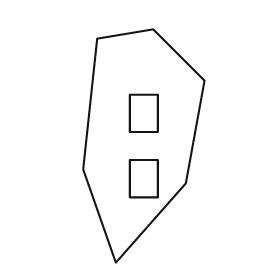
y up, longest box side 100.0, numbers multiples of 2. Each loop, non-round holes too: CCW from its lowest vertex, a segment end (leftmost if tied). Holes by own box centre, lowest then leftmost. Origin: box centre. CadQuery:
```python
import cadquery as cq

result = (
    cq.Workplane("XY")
    .moveTo(-12.0, -50.0)
    .lineTo(18.0, -16.0)
    .lineTo(26.0, 28.0)
    .lineTo(4.0, 50.0)
    .lineTo(-20.0, 46.0)
    .lineTo(-26.0, -10.0)
    .close()
    .moveTo(-6.0, -22.0)
    .lineTo(6.0, -22.0)
    .lineTo(6.0, -6.0)
    .lineTo(-6.0, -6.0)
    .close()
    .moveTo(-6.0, 6.0)
    .lineTo(6.0, 6.0)
    .lineTo(6.0, 22.0)
    .lineTo(-6.0, 22.0)
    .close()
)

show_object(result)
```